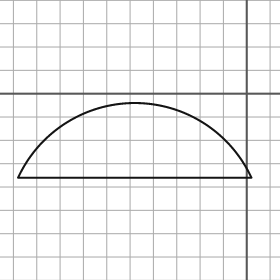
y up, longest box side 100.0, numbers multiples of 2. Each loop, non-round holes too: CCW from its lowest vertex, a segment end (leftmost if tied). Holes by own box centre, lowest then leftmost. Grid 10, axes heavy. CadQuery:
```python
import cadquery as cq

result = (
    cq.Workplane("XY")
    .moveTo(-98.0, -36.0)
    .lineTo(2.0, -36.0)
    .threePointArc((-48.0, -4.0), (-98.0, -36.0))
    .close()
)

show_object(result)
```